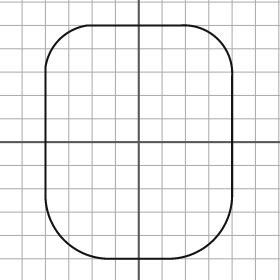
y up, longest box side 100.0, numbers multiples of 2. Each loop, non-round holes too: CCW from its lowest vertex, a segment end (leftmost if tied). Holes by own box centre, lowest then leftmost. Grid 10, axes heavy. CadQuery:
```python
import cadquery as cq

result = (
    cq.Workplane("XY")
    .moveTo(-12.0, -50.0)
    .lineTo(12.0, -50.0)
    .threePointArc((32.0, -42.0), (40.0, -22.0))
    .lineTo(40.0, 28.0)
    .threePointArc((34.0, 44.0), (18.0, 50.0))
    .lineTo(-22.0, 50.0)
    .threePointArc((-34.0, 44.0), (-40.0, 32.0))
    .lineTo(-40.0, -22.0)
    .threePointArc((-32.0, -42.0), (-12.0, -50.0))
    .close()
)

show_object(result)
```